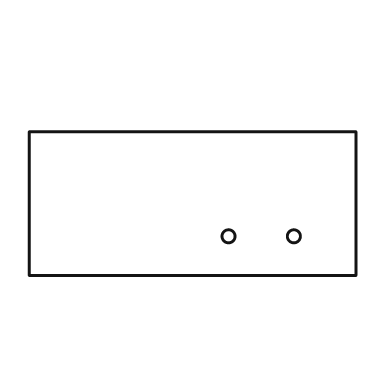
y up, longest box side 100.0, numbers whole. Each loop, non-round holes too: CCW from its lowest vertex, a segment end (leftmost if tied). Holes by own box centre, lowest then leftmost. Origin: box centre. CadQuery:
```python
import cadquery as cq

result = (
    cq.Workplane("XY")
    .moveTo(-50.0, -22.0)
    .lineTo(50.0, -22.0)
    .lineTo(50.0, 22.0)
    .lineTo(-50.0, 22.0)
    .close()
    .moveTo(11.0, -10.0)
    .circle(2.0)
    .moveTo(31.0, -10.0)
    .circle(2.0)
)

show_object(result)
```